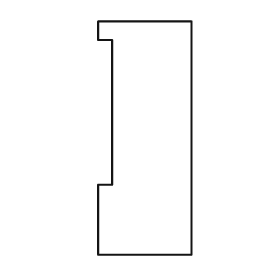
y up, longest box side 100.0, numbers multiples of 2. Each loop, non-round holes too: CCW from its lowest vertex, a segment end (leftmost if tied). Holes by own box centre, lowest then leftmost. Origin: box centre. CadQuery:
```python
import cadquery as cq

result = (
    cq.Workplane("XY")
    .moveTo(-20.0, -50.0)
    .lineTo(20.0, -50.0)
    .lineTo(20.0, 50.0)
    .lineTo(-20.0, 50.0)
    .lineTo(-20.0, 42.0)
    .lineTo(-14.0, 42.0)
    .lineTo(-14.0, -20.0)
    .lineTo(-20.0, -20.0)
    .close()
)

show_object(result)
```